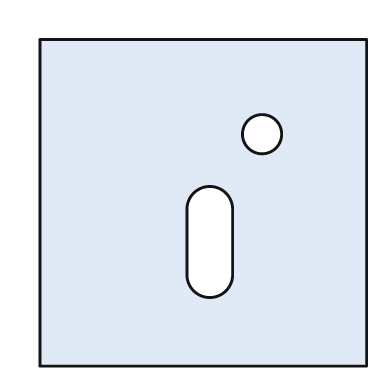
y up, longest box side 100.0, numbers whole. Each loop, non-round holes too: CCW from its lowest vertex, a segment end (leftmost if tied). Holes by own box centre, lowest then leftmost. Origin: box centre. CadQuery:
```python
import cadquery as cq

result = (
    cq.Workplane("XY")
    .moveTo(-50.0, -50.0)
    .lineTo(50.0, -50.0)
    .lineTo(50.0, 50.0)
    .lineTo(-50.0, 50.0)
    .close()
    .moveTo(-5.0, -22.0)
    .threePointArc((2.0, -29.0), (9.0, -22.0))
    .lineTo(9.0, -2.0)
    .threePointArc((2.0, 5.0), (-5.0, -2.0))
    .close()
    .moveTo(18.0, 21.0)
    .circle(6.0)
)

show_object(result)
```